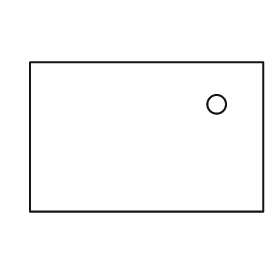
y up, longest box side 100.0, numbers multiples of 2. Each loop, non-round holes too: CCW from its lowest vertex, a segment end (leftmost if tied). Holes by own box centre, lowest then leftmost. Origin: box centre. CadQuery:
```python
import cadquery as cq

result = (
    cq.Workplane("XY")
    .moveTo(-50.0, -32.0)
    .lineTo(50.0, -32.0)
    .lineTo(50.0, 32.0)
    .lineTo(-50.0, 32.0)
    .close()
    .moveTo(30.0, 14.0)
    .circle(4.0)
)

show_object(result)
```